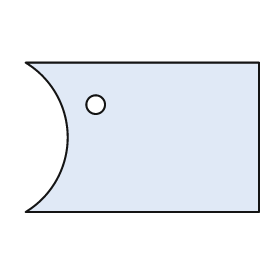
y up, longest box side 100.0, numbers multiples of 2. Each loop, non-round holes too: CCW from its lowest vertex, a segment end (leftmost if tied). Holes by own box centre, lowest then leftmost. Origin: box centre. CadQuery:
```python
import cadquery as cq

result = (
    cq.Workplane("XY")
    .moveTo(-50.0, -32.0)
    .lineTo(50.0, -32.0)
    .lineTo(50.0, 32.0)
    .lineTo(-50.0, 32.0)
    .threePointArc((-32.0, 0.0), (-50.0, -32.0))
    .close()
    .moveTo(-20.0, 14.0)
    .circle(4.0)
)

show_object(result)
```